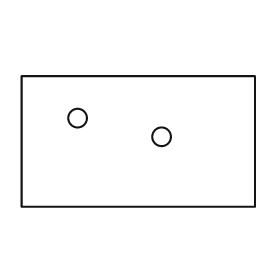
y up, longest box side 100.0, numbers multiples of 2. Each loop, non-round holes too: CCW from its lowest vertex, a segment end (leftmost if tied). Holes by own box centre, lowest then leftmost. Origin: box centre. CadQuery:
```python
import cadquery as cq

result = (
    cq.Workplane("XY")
    .moveTo(-50.0, -28.0)
    .lineTo(50.0, -28.0)
    .lineTo(50.0, 28.0)
    .lineTo(-50.0, 28.0)
    .close()
    .moveTo(10.0, 2.0)
    .circle(4.0)
    .moveTo(-26.0, 10.0)
    .circle(4.0)
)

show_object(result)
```